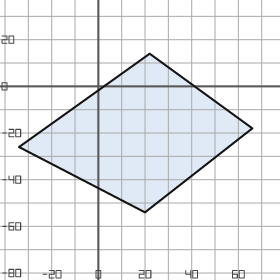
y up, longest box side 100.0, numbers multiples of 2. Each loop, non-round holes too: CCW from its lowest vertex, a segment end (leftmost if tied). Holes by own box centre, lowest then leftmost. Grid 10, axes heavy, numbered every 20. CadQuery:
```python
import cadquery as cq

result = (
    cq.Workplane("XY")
    .moveTo(20.0, -54.0)
    .lineTo(66.0, -18.0)
    .lineTo(22.0, 14.0)
    .lineTo(-34.0, -26.0)
    .close()
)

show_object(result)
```